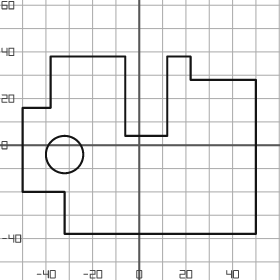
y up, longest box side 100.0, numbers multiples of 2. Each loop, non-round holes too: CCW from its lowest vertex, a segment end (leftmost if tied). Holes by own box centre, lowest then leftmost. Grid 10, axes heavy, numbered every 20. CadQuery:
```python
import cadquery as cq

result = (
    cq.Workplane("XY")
    .moveTo(-32.0, -38.0)
    .lineTo(50.0, -38.0)
    .lineTo(50.0, 28.0)
    .lineTo(22.0, 28.0)
    .lineTo(22.0, 38.0)
    .lineTo(12.0, 38.0)
    .lineTo(12.0, 4.0)
    .lineTo(-6.0, 4.0)
    .lineTo(-6.0, 38.0)
    .lineTo(-38.0, 38.0)
    .lineTo(-38.0, 16.0)
    .lineTo(-50.0, 16.0)
    .lineTo(-50.0, -20.0)
    .lineTo(-32.0, -20.0)
    .close()
    .moveTo(-32.0, -4.0)
    .circle(8.0)
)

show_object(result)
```